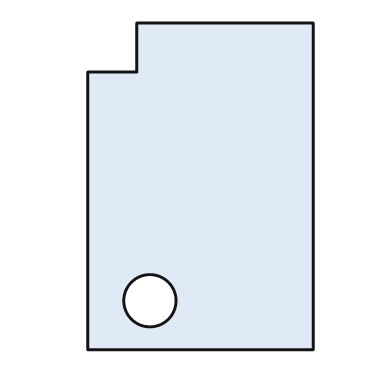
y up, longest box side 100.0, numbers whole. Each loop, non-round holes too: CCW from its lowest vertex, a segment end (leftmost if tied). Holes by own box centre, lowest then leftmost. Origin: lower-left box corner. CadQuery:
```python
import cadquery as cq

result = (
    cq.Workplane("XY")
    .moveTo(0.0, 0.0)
    .lineTo(69.0, 0.0)
    .lineTo(69.0, 100.0)
    .lineTo(15.0, 100.0)
    .lineTo(15.0, 85.0)
    .lineTo(0.0, 85.0)
    .close()
    .moveTo(19.0, 15.0)
    .circle(8.0)
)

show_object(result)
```